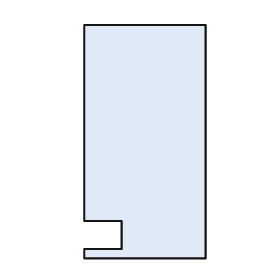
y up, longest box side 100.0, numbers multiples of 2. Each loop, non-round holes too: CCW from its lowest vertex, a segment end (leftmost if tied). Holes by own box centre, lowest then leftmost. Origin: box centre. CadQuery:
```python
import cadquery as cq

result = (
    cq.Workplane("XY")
    .moveTo(-26.0, -50.0)
    .lineTo(26.0, -50.0)
    .lineTo(26.0, 50.0)
    .lineTo(-26.0, 50.0)
    .lineTo(-26.0, -34.0)
    .lineTo(-10.0, -34.0)
    .lineTo(-10.0, -46.0)
    .lineTo(-26.0, -46.0)
    .close()
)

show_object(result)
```